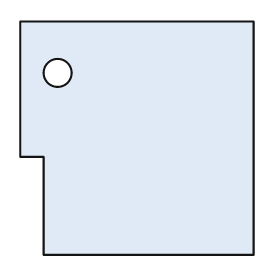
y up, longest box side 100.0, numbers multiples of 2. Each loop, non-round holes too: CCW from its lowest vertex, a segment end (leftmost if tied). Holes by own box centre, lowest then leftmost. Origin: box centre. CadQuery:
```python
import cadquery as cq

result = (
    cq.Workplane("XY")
    .moveTo(-40.0, -50.0)
    .lineTo(50.0, -50.0)
    .lineTo(50.0, 50.0)
    .lineTo(-50.0, 50.0)
    .lineTo(-50.0, -8.0)
    .lineTo(-40.0, -8.0)
    .close()
    .moveTo(-34.0, 28.0)
    .circle(6.0)
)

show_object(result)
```